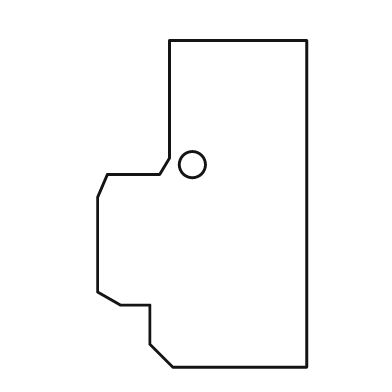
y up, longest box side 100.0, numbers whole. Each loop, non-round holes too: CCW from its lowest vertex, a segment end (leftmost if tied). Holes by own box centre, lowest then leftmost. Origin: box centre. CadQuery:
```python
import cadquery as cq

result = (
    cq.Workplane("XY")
    .moveTo(-9.0, -50.0)
    .lineTo(32.0, -50.0)
    .lineTo(32.0, 50.0)
    .lineTo(-10.0, 50.0)
    .lineTo(-10.0, 14.0)
    .lineTo(-13.0, 9.0)
    .lineTo(-29.0, 9.0)
    .lineTo(-32.0, 2.0)
    .lineTo(-32.0, -27.0)
    .lineTo(-25.0, -31.0)
    .lineTo(-16.0, -31.0)
    .lineTo(-16.0, -43.0)
    .close()
    .moveTo(-3.0, 12.0)
    .circle(4.0)
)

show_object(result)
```